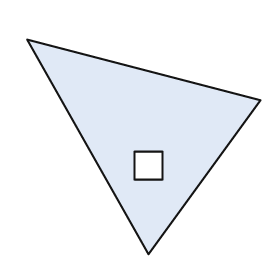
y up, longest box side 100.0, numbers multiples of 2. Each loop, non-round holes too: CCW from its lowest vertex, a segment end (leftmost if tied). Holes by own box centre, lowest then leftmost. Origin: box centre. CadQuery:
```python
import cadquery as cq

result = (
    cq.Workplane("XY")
    .moveTo(2.0, -46.0)
    .lineTo(50.0, 20.0)
    .lineTo(-50.0, 46.0)
    .close()
    .moveTo(-4.0, -14.0)
    .lineTo(8.0, -14.0)
    .lineTo(8.0, -2.0)
    .lineTo(-4.0, -2.0)
    .close()
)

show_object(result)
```